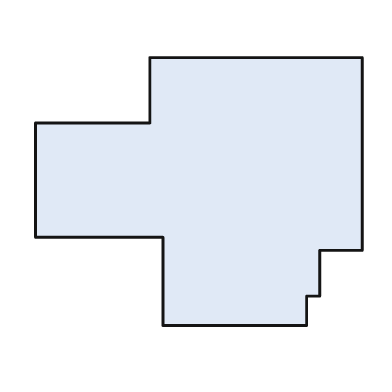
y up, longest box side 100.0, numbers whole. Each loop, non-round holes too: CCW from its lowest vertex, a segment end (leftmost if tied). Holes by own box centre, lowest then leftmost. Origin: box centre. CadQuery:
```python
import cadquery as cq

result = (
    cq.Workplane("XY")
    .moveTo(-11.0, -41.0)
    .lineTo(33.0, -41.0)
    .lineTo(33.0, -32.0)
    .lineTo(37.0, -32.0)
    .lineTo(37.0, -18.0)
    .lineTo(50.0, -18.0)
    .lineTo(50.0, 41.0)
    .lineTo(-15.0, 41.0)
    .lineTo(-15.0, 21.0)
    .lineTo(-50.0, 21.0)
    .lineTo(-50.0, -14.0)
    .lineTo(-11.0, -14.0)
    .close()
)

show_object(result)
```